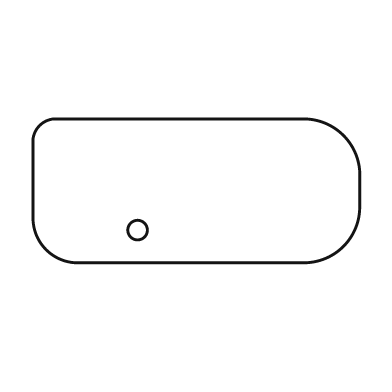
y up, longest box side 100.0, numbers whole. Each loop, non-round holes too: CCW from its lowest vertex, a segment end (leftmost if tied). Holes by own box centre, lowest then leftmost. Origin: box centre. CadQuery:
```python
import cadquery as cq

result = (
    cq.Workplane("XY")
    .moveTo(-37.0, -22.0)
    .lineTo(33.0, -22.0)
    .threePointArc((45.0, -17.0), (50.0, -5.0))
    .lineTo(50.0, 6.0)
    .threePointArc((45.0, 17.0), (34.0, 22.0))
    .lineTo(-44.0, 22.0)
    .threePointArc((-48.0, 20.0), (-50.0, 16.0))
    .lineTo(-50.0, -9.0)
    .threePointArc((-46.0, -18.0), (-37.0, -22.0))
    .close()
    .moveTo(-18.0, -12.0)
    .circle(3.0)
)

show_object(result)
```